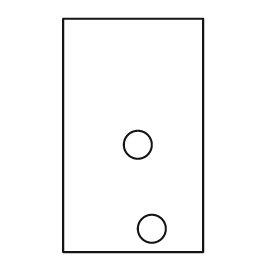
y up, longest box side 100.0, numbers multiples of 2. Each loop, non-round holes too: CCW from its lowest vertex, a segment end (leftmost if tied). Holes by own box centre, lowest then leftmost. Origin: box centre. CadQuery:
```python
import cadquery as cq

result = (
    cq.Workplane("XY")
    .moveTo(-30.0, -50.0)
    .lineTo(30.0, -50.0)
    .lineTo(30.0, 50.0)
    .lineTo(-30.0, 50.0)
    .close()
    .moveTo(8.0, -40.0)
    .circle(6.0)
    .moveTo(2.0, -4.0)
    .circle(6.0)
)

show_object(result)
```